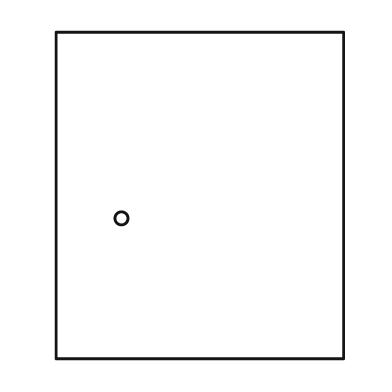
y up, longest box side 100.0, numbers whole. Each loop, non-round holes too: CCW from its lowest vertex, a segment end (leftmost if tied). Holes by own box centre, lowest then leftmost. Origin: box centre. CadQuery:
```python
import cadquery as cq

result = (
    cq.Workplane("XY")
    .moveTo(-44.0, -50.0)
    .lineTo(44.0, -50.0)
    .lineTo(44.0, 50.0)
    .lineTo(-44.0, 50.0)
    .close()
    .moveTo(-24.0, -7.0)
    .circle(2.0)
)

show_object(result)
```